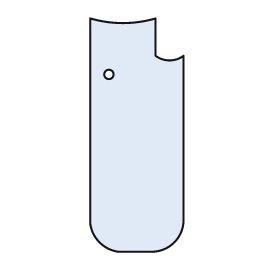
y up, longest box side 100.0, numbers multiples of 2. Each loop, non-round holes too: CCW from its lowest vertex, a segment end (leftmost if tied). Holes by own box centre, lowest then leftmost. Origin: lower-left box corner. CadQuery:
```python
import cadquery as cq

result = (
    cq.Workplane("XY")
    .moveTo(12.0, 0.0)
    .lineTo(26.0, 0.0)
    .threePointArc((36.0, 4.0), (40.0, 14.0))
    .lineTo(40.0, 84.0)
    .threePointArc((34.0, 82.0), (28.0, 84.0))
    .lineTo(28.0, 100.0)
    .threePointArc((14.0, 98.0), (0.0, 100.0))
    .lineTo(0.0, 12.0)
    .threePointArc((4.0, 4.0), (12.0, 0.0))
    .close()
    .moveTo(8.0, 76.0)
    .circle(2.0)
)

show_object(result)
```